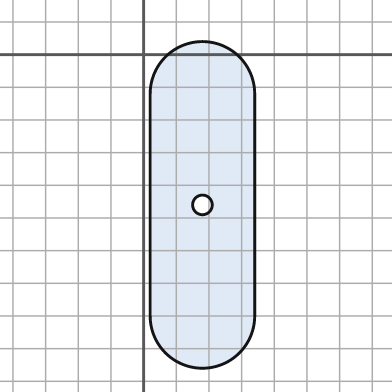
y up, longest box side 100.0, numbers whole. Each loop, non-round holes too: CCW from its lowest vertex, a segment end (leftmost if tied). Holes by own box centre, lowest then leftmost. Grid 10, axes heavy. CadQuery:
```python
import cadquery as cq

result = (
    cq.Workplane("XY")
    .moveTo(2.0, -80.0)
    .threePointArc((18.0, -96.0), (34.0, -80.0))
    .lineTo(34.0, -12.0)
    .threePointArc((18.0, 4.0), (2.0, -12.0))
    .close()
    .moveTo(18.0, -46.0)
    .circle(3.0)
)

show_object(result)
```